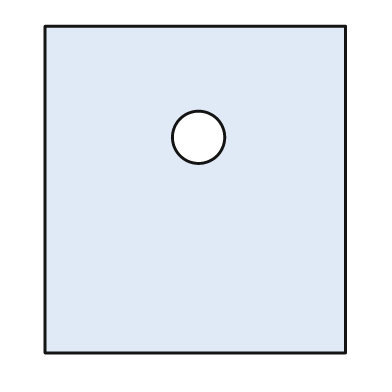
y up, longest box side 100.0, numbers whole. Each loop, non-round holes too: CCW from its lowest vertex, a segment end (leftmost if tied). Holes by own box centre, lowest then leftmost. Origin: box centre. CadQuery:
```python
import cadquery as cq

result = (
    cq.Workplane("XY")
    .moveTo(-46.0, -50.0)
    .lineTo(46.0, -50.0)
    .lineTo(46.0, 50.0)
    .lineTo(-46.0, 50.0)
    .close()
    .moveTo(1.0, 16.0)
    .circle(8.0)
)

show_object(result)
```